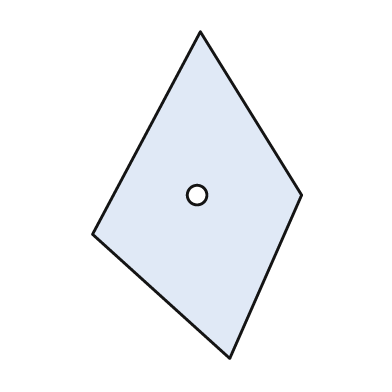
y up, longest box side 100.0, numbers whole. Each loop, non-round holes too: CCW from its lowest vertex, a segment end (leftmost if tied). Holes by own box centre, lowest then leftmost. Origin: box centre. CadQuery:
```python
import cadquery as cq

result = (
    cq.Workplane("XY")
    .moveTo(10.0, -50.0)
    .lineTo(32.0, 0.0)
    .lineTo(1.0, 50.0)
    .lineTo(-32.0, -12.0)
    .close()
    .moveTo(0.0, 0.0)
    .circle(3.0)
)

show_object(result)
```